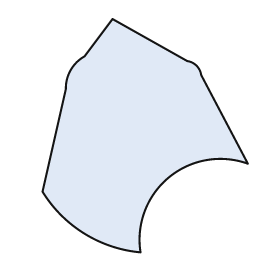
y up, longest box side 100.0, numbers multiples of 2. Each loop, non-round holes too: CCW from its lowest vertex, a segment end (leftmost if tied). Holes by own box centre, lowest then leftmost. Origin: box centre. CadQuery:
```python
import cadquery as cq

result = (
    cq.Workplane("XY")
    .moveTo(-2.0, -50.0)
    .threePointArc((10.0, -18.0), (44.0, -12.0))
    .lineTo(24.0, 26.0)
    .threePointArc((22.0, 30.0), (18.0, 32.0))
    .lineTo(-14.0, 50.0)
    .lineTo(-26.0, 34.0)
    .threePointArc((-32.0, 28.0), (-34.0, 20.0))
    .lineTo(-44.0, -24.0)
    .threePointArc((-26.0, -42.0), (-2.0, -50.0))
    .close()
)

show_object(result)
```